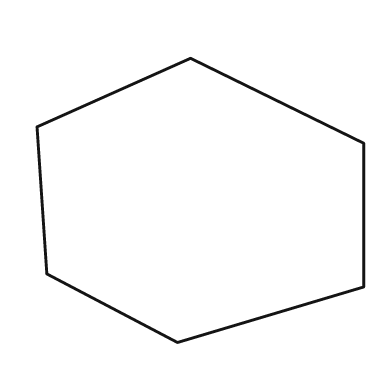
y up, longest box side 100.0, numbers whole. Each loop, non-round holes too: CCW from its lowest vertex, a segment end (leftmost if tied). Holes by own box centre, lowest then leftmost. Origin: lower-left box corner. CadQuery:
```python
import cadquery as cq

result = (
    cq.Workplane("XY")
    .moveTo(43.0, 0.0)
    .lineTo(100.0, 17.0)
    .lineTo(100.0, 61.0)
    .lineTo(47.0, 87.0)
    .lineTo(0.0, 66.0)
    .lineTo(3.0, 21.0)
    .close()
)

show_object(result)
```